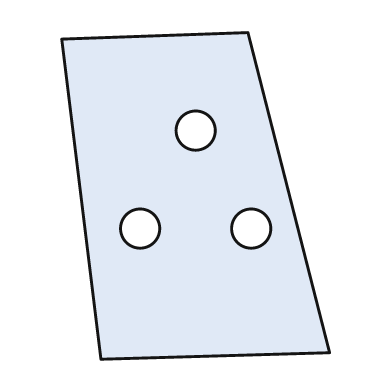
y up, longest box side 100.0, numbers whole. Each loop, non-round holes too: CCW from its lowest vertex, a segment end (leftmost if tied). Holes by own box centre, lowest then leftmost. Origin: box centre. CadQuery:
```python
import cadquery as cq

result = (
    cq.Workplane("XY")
    .moveTo(-29.0, -50.0)
    .lineTo(41.0, -48.0)
    .lineTo(16.0, 50.0)
    .lineTo(-41.0, 48.0)
    .close()
    .moveTo(-17.0, -10.0)
    .circle(6.0)
    .moveTo(17.0, -10.0)
    .circle(6.0)
    .moveTo(0.0, 20.0)
    .circle(6.0)
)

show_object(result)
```